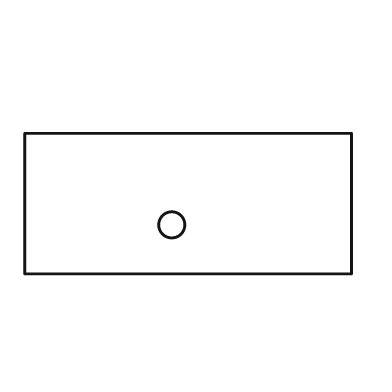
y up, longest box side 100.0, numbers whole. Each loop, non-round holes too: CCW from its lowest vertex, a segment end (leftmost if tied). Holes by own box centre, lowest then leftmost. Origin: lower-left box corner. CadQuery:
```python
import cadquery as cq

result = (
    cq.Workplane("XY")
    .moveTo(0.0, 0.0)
    .lineTo(100.0, 0.0)
    .lineTo(100.0, 43.0)
    .lineTo(0.0, 43.0)
    .close()
    .moveTo(45.0, 15.0)
    .circle(4.0)
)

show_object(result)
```